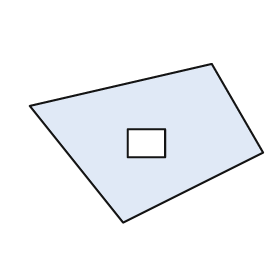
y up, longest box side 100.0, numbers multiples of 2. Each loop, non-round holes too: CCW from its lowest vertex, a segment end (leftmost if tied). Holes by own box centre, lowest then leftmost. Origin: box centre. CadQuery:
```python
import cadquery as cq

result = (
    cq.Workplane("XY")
    .moveTo(-10.0, -34.0)
    .lineTo(50.0, -4.0)
    .lineTo(28.0, 34.0)
    .lineTo(-50.0, 16.0)
    .close()
    .moveTo(-8.0, -6.0)
    .lineTo(8.0, -6.0)
    .lineTo(8.0, 6.0)
    .lineTo(-8.0, 6.0)
    .close()
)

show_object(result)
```